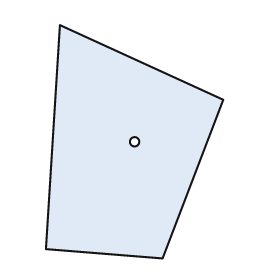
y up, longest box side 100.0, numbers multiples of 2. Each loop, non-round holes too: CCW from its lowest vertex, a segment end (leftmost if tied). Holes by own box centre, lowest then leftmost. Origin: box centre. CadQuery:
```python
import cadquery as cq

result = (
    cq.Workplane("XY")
    .moveTo(12.0, -50.0)
    .lineTo(38.0, 18.0)
    .lineTo(-32.0, 50.0)
    .lineTo(-38.0, -46.0)
    .close()
    .moveTo(0.0, 0.0)
    .circle(2.0)
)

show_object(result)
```